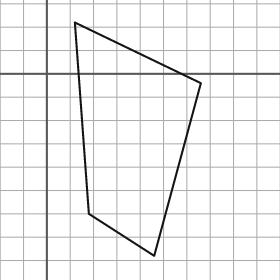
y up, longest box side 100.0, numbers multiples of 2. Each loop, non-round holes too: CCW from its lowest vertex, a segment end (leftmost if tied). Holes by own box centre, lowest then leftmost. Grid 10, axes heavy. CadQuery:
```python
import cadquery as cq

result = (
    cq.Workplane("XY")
    .moveTo(46.0, -78.0)
    .lineTo(66.0, -4.0)
    .lineTo(12.0, 22.0)
    .lineTo(18.0, -60.0)
    .close()
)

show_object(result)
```